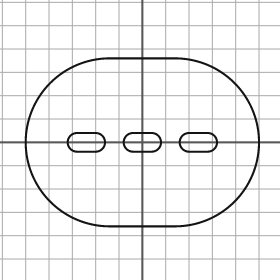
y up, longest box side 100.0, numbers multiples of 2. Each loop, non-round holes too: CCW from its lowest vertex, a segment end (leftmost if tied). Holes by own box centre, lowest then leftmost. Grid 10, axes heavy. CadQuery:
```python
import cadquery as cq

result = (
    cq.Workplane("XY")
    .moveTo(-14.0, -36.0)
    .lineTo(14.0, -36.0)
    .threePointArc((50.0, 0.0), (14.0, 36.0))
    .lineTo(-14.0, 36.0)
    .threePointArc((-50.0, 0.0), (-14.0, -36.0))
    .close()
    .moveTo(-28.0, -4.0)
    .lineTo(-20.0, -4.0)
    .threePointArc((-16.0, 0.0), (-20.0, 4.0))
    .lineTo(-28.0, 4.0)
    .threePointArc((-32.0, 0.0), (-28.0, -4.0))
    .close()
    .moveTo(-4.0, -4.0)
    .lineTo(4.0, -4.0)
    .threePointArc((8.0, 0.0), (4.0, 4.0))
    .lineTo(-4.0, 4.0)
    .threePointArc((-8.0, 0.0), (-4.0, -4.0))
    .close()
    .moveTo(20.0, -4.0)
    .lineTo(28.0, -4.0)
    .threePointArc((32.0, 0.0), (28.0, 4.0))
    .lineTo(20.0, 4.0)
    .threePointArc((16.0, 0.0), (20.0, -4.0))
    .close()
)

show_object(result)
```